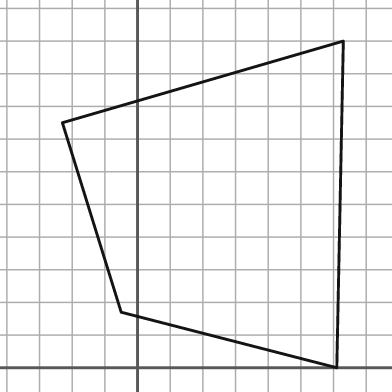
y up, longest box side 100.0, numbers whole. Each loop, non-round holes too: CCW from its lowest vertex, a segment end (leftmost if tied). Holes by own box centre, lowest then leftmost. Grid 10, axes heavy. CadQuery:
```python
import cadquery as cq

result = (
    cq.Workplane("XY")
    .moveTo(61.0, 0.0)
    .lineTo(63.0, 100.0)
    .lineTo(-23.0, 75.0)
    .lineTo(-5.0, 17.0)
    .close()
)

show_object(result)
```